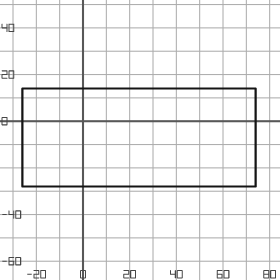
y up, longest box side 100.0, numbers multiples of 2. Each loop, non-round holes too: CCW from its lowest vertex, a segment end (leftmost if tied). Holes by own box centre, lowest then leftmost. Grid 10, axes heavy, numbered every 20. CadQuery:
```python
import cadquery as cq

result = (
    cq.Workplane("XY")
    .moveTo(-26.0, -28.0)
    .lineTo(74.0, -28.0)
    .lineTo(74.0, 14.0)
    .lineTo(-26.0, 14.0)
    .close()
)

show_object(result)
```